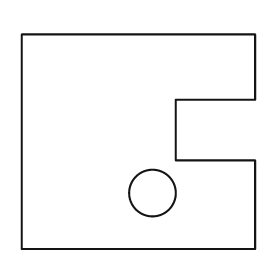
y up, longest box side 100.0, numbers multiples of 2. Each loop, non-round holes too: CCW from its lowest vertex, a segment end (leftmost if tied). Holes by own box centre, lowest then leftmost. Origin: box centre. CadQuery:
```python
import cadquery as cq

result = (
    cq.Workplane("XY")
    .moveTo(-50.0, -46.0)
    .lineTo(50.0, -46.0)
    .lineTo(50.0, -8.0)
    .lineTo(16.0, -8.0)
    .lineTo(16.0, 18.0)
    .lineTo(50.0, 18.0)
    .lineTo(50.0, 46.0)
    .lineTo(-50.0, 46.0)
    .close()
    .moveTo(6.0, -22.0)
    .circle(10.0)
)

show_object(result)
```